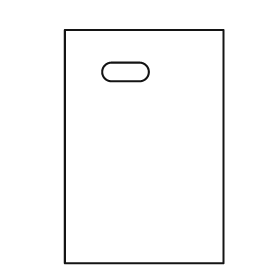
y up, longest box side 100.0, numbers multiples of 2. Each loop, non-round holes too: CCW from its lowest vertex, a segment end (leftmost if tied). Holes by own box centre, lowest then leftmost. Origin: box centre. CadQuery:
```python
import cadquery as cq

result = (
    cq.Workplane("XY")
    .moveTo(-34.0, -50.0)
    .lineTo(34.0, -50.0)
    .lineTo(34.0, 50.0)
    .lineTo(-34.0, 50.0)
    .close()
    .moveTo(-14.0, 28.0)
    .lineTo(-2.0, 28.0)
    .threePointArc((2.0, 32.0), (-2.0, 36.0))
    .lineTo(-14.0, 36.0)
    .threePointArc((-18.0, 32.0), (-14.0, 28.0))
    .close()
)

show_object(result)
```